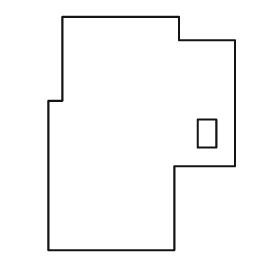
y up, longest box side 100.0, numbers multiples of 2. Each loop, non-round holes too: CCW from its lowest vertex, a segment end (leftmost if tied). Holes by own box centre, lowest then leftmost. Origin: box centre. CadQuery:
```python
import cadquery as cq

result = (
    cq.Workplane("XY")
    .moveTo(-40.0, -50.0)
    .lineTo(14.0, -50.0)
    .lineTo(14.0, -14.0)
    .lineTo(40.0, -14.0)
    .lineTo(40.0, 40.0)
    .lineTo(16.0, 40.0)
    .lineTo(16.0, 50.0)
    .lineTo(-34.0, 50.0)
    .lineTo(-34.0, 14.0)
    .lineTo(-40.0, 14.0)
    .close()
    .moveTo(24.0, -6.0)
    .lineTo(32.0, -6.0)
    .lineTo(32.0, 6.0)
    .lineTo(24.0, 6.0)
    .close()
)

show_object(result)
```